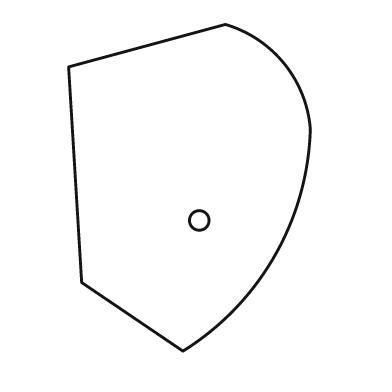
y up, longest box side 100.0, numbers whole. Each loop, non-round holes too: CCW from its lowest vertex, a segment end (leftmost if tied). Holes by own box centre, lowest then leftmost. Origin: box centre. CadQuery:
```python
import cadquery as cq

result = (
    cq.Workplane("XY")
    .moveTo(-2.0, -50.0)
    .threePointArc((26.0, -21.0), (37.0, 18.0))
    .threePointArc((29.0, 38.0), (11.0, 50.0))
    .lineTo(-37.0, 37.0)
    .lineTo(-33.0, -29.0)
    .close()
    .moveTo(3.0, -10.0)
    .circle(3.0)
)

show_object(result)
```